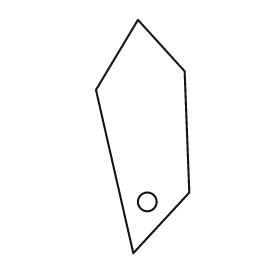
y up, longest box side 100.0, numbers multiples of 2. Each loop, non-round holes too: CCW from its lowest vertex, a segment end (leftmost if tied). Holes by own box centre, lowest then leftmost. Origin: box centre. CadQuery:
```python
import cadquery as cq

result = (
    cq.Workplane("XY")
    .moveTo(-4.0, -50.0)
    .lineTo(20.0, -24.0)
    .lineTo(18.0, 28.0)
    .lineTo(-2.0, 50.0)
    .lineTo(-20.0, 20.0)
    .close()
    .moveTo(2.0, -28.0)
    .circle(4.0)
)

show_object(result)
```